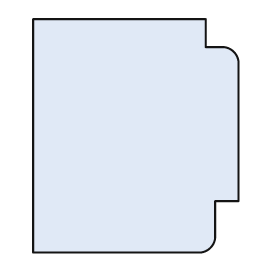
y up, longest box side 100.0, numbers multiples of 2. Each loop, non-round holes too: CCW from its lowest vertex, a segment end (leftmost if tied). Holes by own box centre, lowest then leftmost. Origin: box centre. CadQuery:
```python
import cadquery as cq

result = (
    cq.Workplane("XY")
    .moveTo(-44.0, -50.0)
    .lineTo(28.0, -50.0)
    .threePointArc((32.0, -48.0), (34.0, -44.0))
    .lineTo(34.0, -28.0)
    .lineTo(44.0, -28.0)
    .lineTo(44.0, 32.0)
    .threePointArc((42.0, 36.0), (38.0, 38.0))
    .lineTo(30.0, 38.0)
    .lineTo(30.0, 50.0)
    .lineTo(-44.0, 50.0)
    .close()
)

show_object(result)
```